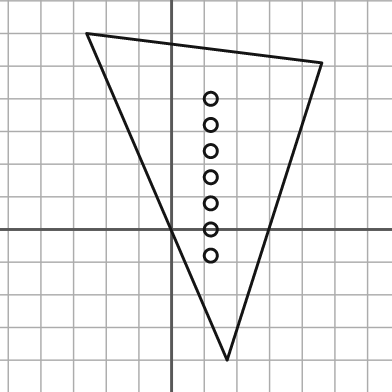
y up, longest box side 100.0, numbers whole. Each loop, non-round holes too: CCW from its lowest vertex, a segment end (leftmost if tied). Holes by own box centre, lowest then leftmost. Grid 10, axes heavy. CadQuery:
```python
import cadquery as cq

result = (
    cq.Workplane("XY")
    .moveTo(17.0, -40.0)
    .lineTo(46.0, 51.0)
    .lineTo(-26.0, 60.0)
    .close()
    .moveTo(12.0, -8.0)
    .circle(2.0)
    .moveTo(12.0, 0.0)
    .circle(2.0)
    .moveTo(12.0, 8.0)
    .circle(2.0)
    .moveTo(12.0, 16.0)
    .circle(2.0)
    .moveTo(12.0, 24.0)
    .circle(2.0)
    .moveTo(12.0, 32.0)
    .circle(2.0)
    .moveTo(12.0, 40.0)
    .circle(2.0)
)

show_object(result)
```